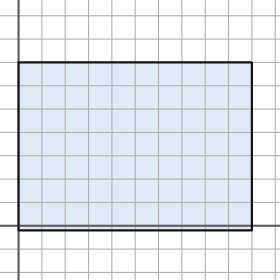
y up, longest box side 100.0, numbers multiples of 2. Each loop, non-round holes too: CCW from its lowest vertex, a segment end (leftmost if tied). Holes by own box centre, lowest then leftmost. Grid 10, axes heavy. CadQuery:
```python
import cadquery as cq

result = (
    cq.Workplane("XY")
    .moveTo(0.0, -2.0)
    .lineTo(100.0, -2.0)
    .lineTo(100.0, 70.0)
    .lineTo(0.0, 70.0)
    .close()
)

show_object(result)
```